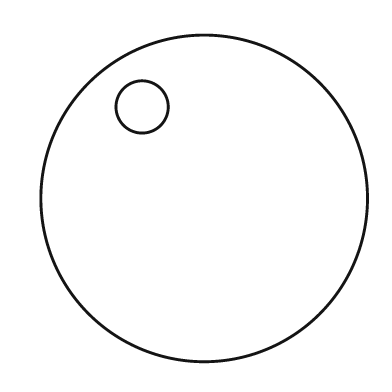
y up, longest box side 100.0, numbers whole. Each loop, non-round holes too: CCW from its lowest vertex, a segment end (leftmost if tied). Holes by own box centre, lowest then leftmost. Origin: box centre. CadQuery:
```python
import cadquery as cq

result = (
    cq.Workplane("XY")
    .moveTo(0.0, 0.0)
    .circle(50.0)
    .moveTo(-19.0, 28.0)
    .circle(8.0)
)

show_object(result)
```